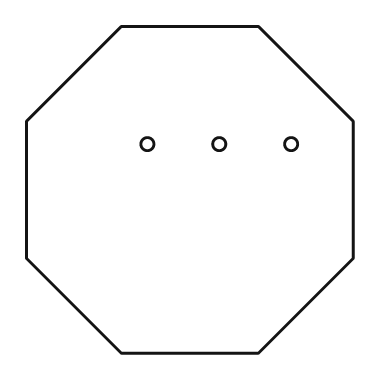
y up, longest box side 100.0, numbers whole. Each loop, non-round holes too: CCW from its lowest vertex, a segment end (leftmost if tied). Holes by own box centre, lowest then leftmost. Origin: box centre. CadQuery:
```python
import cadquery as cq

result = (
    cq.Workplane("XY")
    .moveTo(-21.0, -50.0)
    .lineTo(21.0, -50.0)
    .lineTo(50.0, -21.0)
    .lineTo(50.0, 21.0)
    .lineTo(21.0, 50.0)
    .lineTo(-21.0, 50.0)
    .lineTo(-50.0, 21.0)
    .lineTo(-50.0, -21.0)
    .close()
    .moveTo(-13.0, 14.0)
    .circle(2.0)
    .moveTo(9.0, 14.0)
    .circle(2.0)
    .moveTo(31.0, 14.0)
    .circle(2.0)
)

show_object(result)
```